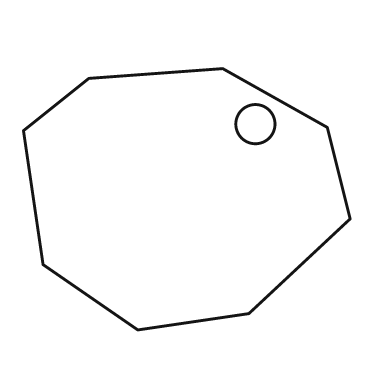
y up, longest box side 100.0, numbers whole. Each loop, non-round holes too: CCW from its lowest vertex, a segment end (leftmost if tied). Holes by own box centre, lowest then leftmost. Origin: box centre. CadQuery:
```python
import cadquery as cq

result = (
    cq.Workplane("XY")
    .moveTo(-15.0, -40.0)
    .lineTo(19.0, -35.0)
    .lineTo(50.0, -6.0)
    .lineTo(43.0, 22.0)
    .lineTo(11.0, 40.0)
    .lineTo(-30.0, 37.0)
    .lineTo(-50.0, 21.0)
    .lineTo(-44.0, -20.0)
    .close()
    .moveTo(21.0, 23.0)
    .circle(6.0)
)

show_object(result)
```